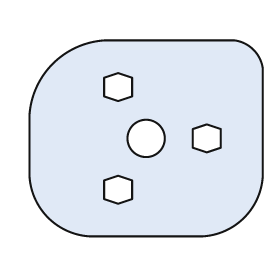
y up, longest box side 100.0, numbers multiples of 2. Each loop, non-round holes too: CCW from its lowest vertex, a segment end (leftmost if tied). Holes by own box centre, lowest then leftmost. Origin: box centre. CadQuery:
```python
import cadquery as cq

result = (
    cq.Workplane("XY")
    .moveTo(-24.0, -42.0)
    .lineTo(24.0, -42.0)
    .threePointArc((42.0, -34.0), (50.0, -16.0))
    .lineTo(50.0, 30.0)
    .threePointArc((46.0, 38.0), (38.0, 42.0))
    .lineTo(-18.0, 42.0)
    .threePointArc((-40.0, 32.0), (-50.0, 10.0))
    .lineTo(-50.0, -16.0)
    .threePointArc((-42.0, -34.0), (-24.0, -42.0))
    .close()
    .moveTo(-12.0, -28.0)
    .lineTo(-6.0, -26.0)
    .lineTo(-6.0, -18.0)
    .lineTo(-12.0, -16.0)
    .lineTo(-18.0, -18.0)
    .lineTo(-18.0, -26.0)
    .close()
    .moveTo(0.0, 0.0)
    .circle(8.0)
    .moveTo(26.0, -6.0)
    .lineTo(32.0, -4.0)
    .lineTo(32.0, 4.0)
    .lineTo(26.0, 6.0)
    .lineTo(20.0, 4.0)
    .lineTo(20.0, -4.0)
    .close()
    .moveTo(-12.0, 16.0)
    .lineTo(-6.0, 18.0)
    .lineTo(-6.0, 26.0)
    .lineTo(-12.0, 28.0)
    .lineTo(-18.0, 26.0)
    .lineTo(-18.0, 18.0)
    .close()
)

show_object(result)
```